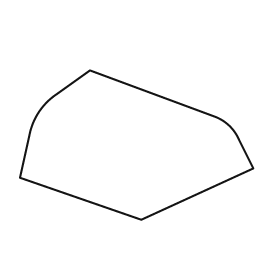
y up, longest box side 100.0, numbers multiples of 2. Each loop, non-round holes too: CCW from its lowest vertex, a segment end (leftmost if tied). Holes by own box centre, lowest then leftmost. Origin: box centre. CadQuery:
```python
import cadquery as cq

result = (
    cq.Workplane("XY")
    .moveTo(2.0, -32.0)
    .lineTo(50.0, -10.0)
    .lineTo(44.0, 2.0)
    .threePointArc((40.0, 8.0), (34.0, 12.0))
    .lineTo(-20.0, 32.0)
    .lineTo(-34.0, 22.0)
    .threePointArc((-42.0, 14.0), (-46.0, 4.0))
    .lineTo(-50.0, -14.0)
    .close()
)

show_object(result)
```